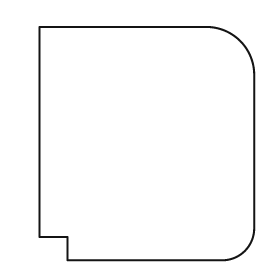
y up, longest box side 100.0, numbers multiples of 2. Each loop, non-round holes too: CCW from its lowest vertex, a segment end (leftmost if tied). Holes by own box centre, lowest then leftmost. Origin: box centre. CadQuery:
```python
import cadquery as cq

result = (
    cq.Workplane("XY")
    .moveTo(-34.0, -50.0)
    .lineTo(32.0, -50.0)
    .threePointArc((42.0, -46.0), (46.0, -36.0))
    .lineTo(46.0, 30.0)
    .threePointArc((40.0, 44.0), (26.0, 50.0))
    .lineTo(-46.0, 50.0)
    .lineTo(-46.0, -40.0)
    .lineTo(-34.0, -40.0)
    .close()
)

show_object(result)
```